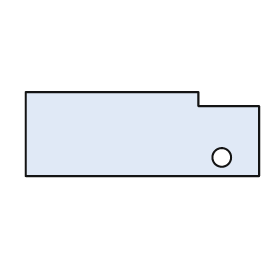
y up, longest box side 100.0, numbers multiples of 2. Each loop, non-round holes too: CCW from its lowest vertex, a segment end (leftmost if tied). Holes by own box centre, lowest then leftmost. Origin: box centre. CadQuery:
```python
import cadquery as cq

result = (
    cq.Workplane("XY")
    .moveTo(-50.0, -18.0)
    .lineTo(50.0, -18.0)
    .lineTo(50.0, 12.0)
    .lineTo(24.0, 12.0)
    .lineTo(24.0, 18.0)
    .lineTo(-50.0, 18.0)
    .close()
    .moveTo(34.0, -10.0)
    .circle(4.0)
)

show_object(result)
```